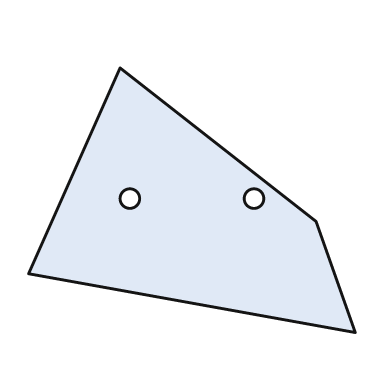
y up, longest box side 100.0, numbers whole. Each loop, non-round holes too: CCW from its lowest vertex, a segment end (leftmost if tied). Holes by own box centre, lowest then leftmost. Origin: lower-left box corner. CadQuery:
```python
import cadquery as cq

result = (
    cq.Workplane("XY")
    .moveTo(100.0, 0.0)
    .lineTo(88.0, 34.0)
    .lineTo(28.0, 81.0)
    .lineTo(0.0, 18.0)
    .close()
    .moveTo(31.0, 41.0)
    .circle(3.0)
    .moveTo(69.0, 41.0)
    .circle(3.0)
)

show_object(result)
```